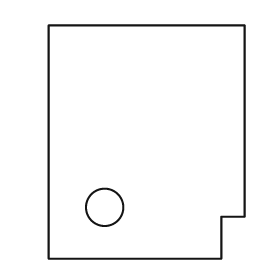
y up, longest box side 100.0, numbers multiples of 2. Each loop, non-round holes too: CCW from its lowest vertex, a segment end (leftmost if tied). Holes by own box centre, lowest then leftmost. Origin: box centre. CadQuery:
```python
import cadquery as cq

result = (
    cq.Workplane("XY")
    .moveTo(-42.0, -50.0)
    .lineTo(32.0, -50.0)
    .lineTo(32.0, -32.0)
    .lineTo(42.0, -32.0)
    .lineTo(42.0, 50.0)
    .lineTo(-42.0, 50.0)
    .close()
    .moveTo(-18.0, -28.0)
    .circle(8.0)
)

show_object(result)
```